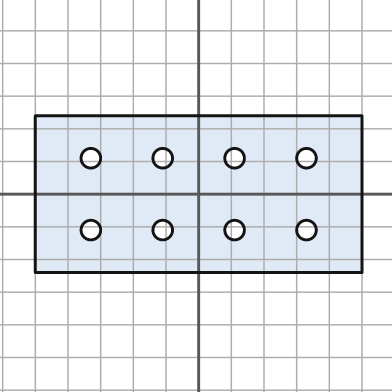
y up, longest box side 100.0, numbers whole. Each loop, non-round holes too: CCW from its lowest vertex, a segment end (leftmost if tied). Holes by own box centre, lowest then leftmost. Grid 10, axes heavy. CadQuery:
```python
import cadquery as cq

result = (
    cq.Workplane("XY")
    .moveTo(-50.0, -24.0)
    .lineTo(50.0, -24.0)
    .lineTo(50.0, 24.0)
    .lineTo(-50.0, 24.0)
    .close()
    .moveTo(-33.0, -11.0)
    .circle(3.0)
    .moveTo(-11.0, -11.0)
    .circle(3.0)
    .moveTo(11.0, -11.0)
    .circle(3.0)
    .moveTo(33.0, -11.0)
    .circle(3.0)
    .moveTo(-33.0, 11.0)
    .circle(3.0)
    .moveTo(-11.0, 11.0)
    .circle(3.0)
    .moveTo(11.0, 11.0)
    .circle(3.0)
    .moveTo(33.0, 11.0)
    .circle(3.0)
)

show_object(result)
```